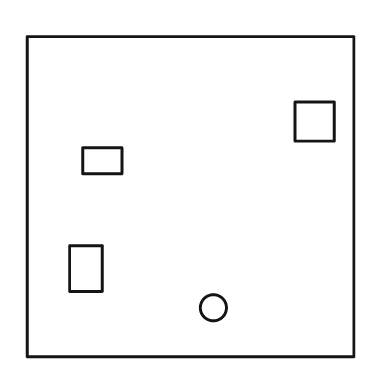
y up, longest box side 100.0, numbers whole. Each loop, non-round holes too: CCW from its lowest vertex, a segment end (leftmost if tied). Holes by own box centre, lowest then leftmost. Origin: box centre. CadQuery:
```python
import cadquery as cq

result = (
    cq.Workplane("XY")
    .moveTo(-50.0, -49.0)
    .lineTo(50.0, -49.0)
    .lineTo(50.0, 49.0)
    .lineTo(-50.0, 49.0)
    .close()
    .moveTo(7.0, -34.0)
    .circle(4.0)
    .moveTo(-37.0, -29.0)
    .lineTo(-27.0, -29.0)
    .lineTo(-27.0, -15.0)
    .lineTo(-37.0, -15.0)
    .close()
    .moveTo(-33.0, 7.0)
    .lineTo(-21.0, 7.0)
    .lineTo(-21.0, 15.0)
    .lineTo(-33.0, 15.0)
    .close()
    .moveTo(32.0, 17.0)
    .lineTo(44.0, 17.0)
    .lineTo(44.0, 29.0)
    .lineTo(32.0, 29.0)
    .close()
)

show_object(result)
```